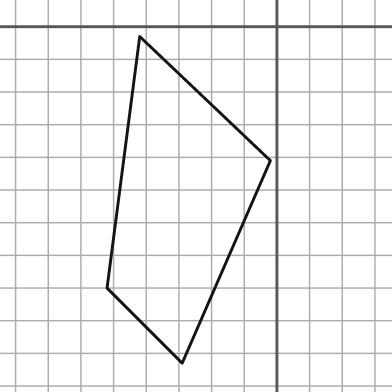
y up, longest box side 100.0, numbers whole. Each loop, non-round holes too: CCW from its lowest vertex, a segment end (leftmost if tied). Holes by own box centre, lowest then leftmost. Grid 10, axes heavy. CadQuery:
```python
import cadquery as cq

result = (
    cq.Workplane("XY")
    .moveTo(-29.0, -103.0)
    .lineTo(-2.0, -41.0)
    .lineTo(-42.0, -3.0)
    .lineTo(-52.0, -80.0)
    .close()
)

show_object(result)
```